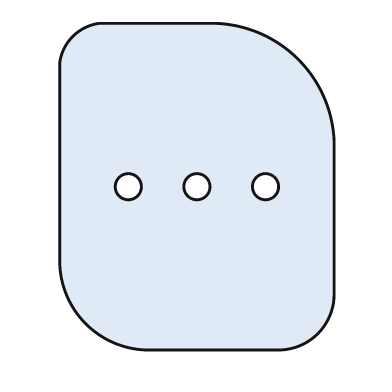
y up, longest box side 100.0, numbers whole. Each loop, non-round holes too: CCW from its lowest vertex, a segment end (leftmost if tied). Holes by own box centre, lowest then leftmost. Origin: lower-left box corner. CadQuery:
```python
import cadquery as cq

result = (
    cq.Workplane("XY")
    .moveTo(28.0, 0.0)
    .lineTo(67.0, 0.0)
    .threePointArc((79.0, 5.0), (84.0, 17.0))
    .lineTo(84.0, 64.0)
    .threePointArc((73.0, 89.0), (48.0, 100.0))
    .lineTo(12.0, 100.0)
    .threePointArc((4.0, 96.0), (0.0, 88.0))
    .lineTo(0.0, 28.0)
    .threePointArc((8.0, 8.0), (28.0, 0.0))
    .close()
    .moveTo(21.0, 50.0)
    .circle(4.0)
    .moveTo(42.0, 50.0)
    .circle(4.0)
    .moveTo(63.0, 50.0)
    .circle(4.0)
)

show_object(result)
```